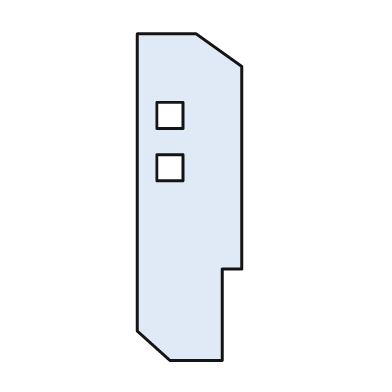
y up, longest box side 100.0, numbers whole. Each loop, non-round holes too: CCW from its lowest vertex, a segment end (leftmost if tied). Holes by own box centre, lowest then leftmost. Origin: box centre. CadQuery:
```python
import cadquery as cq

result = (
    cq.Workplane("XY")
    .moveTo(-6.0, -50.0)
    .lineTo(10.0, -50.0)
    .lineTo(10.0, -22.0)
    .lineTo(16.0, -22.0)
    .lineTo(16.0, 40.0)
    .lineTo(2.0, 50.0)
    .lineTo(-16.0, 50.0)
    .lineTo(-16.0, -41.0)
    .close()
    .moveTo(-10.0, 5.0)
    .lineTo(-2.0, 5.0)
    .lineTo(-2.0, 13.0)
    .lineTo(-10.0, 13.0)
    .close()
    .moveTo(-10.0, 21.0)
    .lineTo(-2.0, 21.0)
    .lineTo(-2.0, 29.0)
    .lineTo(-10.0, 29.0)
    .close()
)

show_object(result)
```